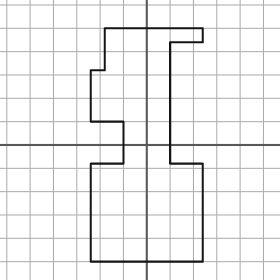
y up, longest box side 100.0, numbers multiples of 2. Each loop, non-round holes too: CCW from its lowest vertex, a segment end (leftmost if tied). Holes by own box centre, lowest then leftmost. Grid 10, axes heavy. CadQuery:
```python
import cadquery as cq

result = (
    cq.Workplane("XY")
    .moveTo(-24.0, -50.0)
    .lineTo(24.0, -50.0)
    .lineTo(24.0, -8.0)
    .lineTo(10.0, -8.0)
    .lineTo(10.0, 44.0)
    .lineTo(24.0, 44.0)
    .lineTo(24.0, 50.0)
    .lineTo(-18.0, 50.0)
    .lineTo(-18.0, 32.0)
    .lineTo(-24.0, 32.0)
    .lineTo(-24.0, 10.0)
    .lineTo(-10.0, 10.0)
    .lineTo(-10.0, -8.0)
    .lineTo(-24.0, -8.0)
    .close()
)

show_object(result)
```